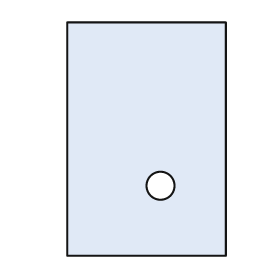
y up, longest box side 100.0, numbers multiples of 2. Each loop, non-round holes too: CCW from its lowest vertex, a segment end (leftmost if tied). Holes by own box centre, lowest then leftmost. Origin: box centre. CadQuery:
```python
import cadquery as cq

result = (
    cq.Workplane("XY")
    .moveTo(-34.0, -50.0)
    .lineTo(34.0, -50.0)
    .lineTo(34.0, 50.0)
    .lineTo(-34.0, 50.0)
    .close()
    .moveTo(6.0, -20.0)
    .circle(6.0)
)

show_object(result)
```